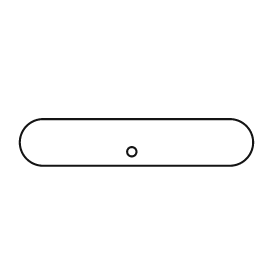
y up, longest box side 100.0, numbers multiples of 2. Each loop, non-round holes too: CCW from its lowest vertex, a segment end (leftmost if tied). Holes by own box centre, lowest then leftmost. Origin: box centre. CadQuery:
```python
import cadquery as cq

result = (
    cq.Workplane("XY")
    .moveTo(-40.0, -10.0)
    .lineTo(40.0, -10.0)
    .threePointArc((50.0, 0.0), (40.0, 10.0))
    .lineTo(-40.0, 10.0)
    .threePointArc((-50.0, 0.0), (-40.0, -10.0))
    .close()
    .moveTo(-2.0, -4.0)
    .circle(2.0)
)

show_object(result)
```